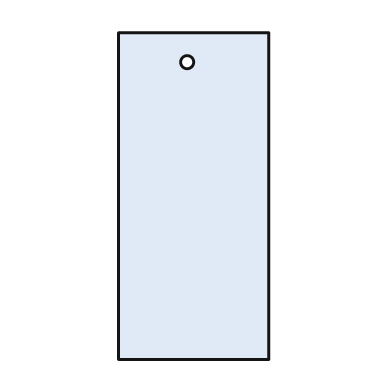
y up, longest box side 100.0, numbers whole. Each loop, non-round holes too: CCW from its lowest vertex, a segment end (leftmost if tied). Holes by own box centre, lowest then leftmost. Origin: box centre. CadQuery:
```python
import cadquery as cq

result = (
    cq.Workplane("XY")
    .moveTo(-23.0, -50.0)
    .lineTo(23.0, -50.0)
    .lineTo(23.0, 50.0)
    .lineTo(-23.0, 50.0)
    .close()
    .moveTo(-2.0, 41.0)
    .circle(2.0)
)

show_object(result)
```